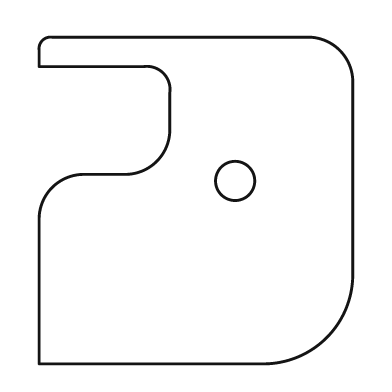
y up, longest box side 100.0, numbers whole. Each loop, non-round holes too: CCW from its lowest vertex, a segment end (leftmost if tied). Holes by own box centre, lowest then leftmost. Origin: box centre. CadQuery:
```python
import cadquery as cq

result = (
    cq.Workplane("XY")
    .moveTo(-48.0, -50.0)
    .lineTo(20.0, -50.0)
    .threePointArc((40.0, -42.0), (48.0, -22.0))
    .lineTo(48.0, 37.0)
    .threePointArc((44.0, 46.0), (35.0, 50.0))
    .lineTo(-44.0, 50.0)
    .threePointArc((-47.0, 49.0), (-48.0, 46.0))
    .lineTo(-48.0, 41.0)
    .lineTo(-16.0, 41.0)
    .threePointArc((-10.0, 39.0), (-8.0, 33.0))
    .lineTo(-8.0, 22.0)
    .threePointArc((-12.0, 12.0), (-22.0, 8.0))
    .lineTo(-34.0, 8.0)
    .threePointArc((-44.0, 4.0), (-48.0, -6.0))
    .close()
    .moveTo(12.0, 6.0)
    .circle(6.0)
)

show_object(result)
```